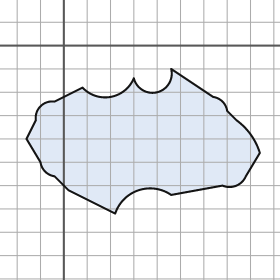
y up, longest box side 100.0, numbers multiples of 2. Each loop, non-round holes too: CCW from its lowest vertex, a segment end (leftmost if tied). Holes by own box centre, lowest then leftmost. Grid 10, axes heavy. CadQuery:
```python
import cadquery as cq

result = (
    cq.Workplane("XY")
    .moveTo(22.0, -72.0)
    .threePointArc((32.0, -62.0), (46.0, -64.0))
    .lineTo(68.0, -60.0)
    .threePointArc((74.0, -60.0), (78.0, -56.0))
    .lineTo(84.0, -46.0)
    .threePointArc((80.0, -38.0), (74.0, -32.0))
    .lineTo(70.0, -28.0)
    .threePointArc((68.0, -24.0), (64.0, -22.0))
    .lineTo(46.0, -10.0)
    .threePointArc((40.0, -20.0), (30.0, -14.0))
    .threePointArc((20.0, -22.0), (8.0, -18.0))
    .lineTo(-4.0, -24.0)
    .threePointArc((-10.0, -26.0), (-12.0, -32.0))
    .lineTo(-16.0, -40.0)
    .lineTo(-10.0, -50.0)
    .threePointArc((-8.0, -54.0), (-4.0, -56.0))
    .lineTo(2.0, -62.0)
    .close()
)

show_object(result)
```